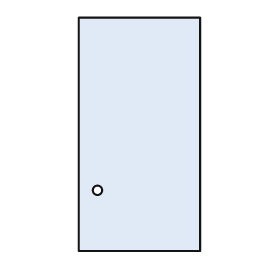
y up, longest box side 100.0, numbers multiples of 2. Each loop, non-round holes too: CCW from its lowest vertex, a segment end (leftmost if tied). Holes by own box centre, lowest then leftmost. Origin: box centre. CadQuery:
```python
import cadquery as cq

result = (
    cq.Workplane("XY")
    .moveTo(-26.0, -50.0)
    .lineTo(26.0, -50.0)
    .lineTo(26.0, 50.0)
    .lineTo(-26.0, 50.0)
    .close()
    .moveTo(-18.0, -24.0)
    .circle(2.0)
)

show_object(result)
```